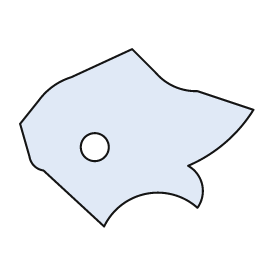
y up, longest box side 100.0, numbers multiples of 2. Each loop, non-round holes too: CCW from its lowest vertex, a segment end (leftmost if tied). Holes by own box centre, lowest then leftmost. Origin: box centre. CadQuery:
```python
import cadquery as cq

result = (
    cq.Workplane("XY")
    .moveTo(-14.0, -38.0)
    .threePointArc((4.0, -24.0), (26.0, -30.0))
    .threePointArc((28.0, -20.0), (22.0, -12.0))
    .threePointArc((38.0, -2.0), (50.0, 12.0))
    .lineTo(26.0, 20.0)
    .threePointArc((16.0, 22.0), (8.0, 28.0))
    .lineTo(-2.0, 38.0)
    .lineTo(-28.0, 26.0)
    .threePointArc((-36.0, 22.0), (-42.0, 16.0))
    .lineTo(-50.0, 6.0)
    .lineTo(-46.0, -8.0)
    .threePointArc((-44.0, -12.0), (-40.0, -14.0))
    .close()
    .moveTo(-18.0, -4.0)
    .circle(6.0)
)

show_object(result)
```